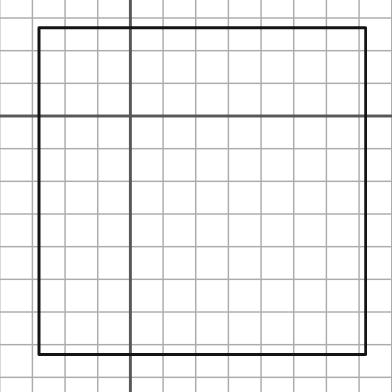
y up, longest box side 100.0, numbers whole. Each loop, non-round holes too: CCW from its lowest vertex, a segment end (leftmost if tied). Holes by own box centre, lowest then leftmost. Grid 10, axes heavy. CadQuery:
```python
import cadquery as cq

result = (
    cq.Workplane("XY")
    .moveTo(-28.0, -73.0)
    .lineTo(72.0, -73.0)
    .lineTo(72.0, 27.0)
    .lineTo(-28.0, 27.0)
    .close()
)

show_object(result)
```